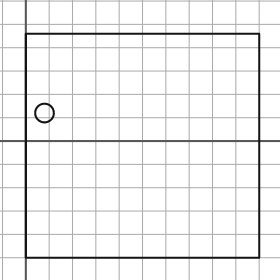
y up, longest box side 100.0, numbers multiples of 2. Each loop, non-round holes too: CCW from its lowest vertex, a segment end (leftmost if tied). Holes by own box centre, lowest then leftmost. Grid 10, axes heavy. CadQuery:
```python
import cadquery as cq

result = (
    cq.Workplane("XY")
    .moveTo(0.0, -50.0)
    .lineTo(100.0, -50.0)
    .lineTo(100.0, 46.0)
    .lineTo(0.0, 46.0)
    .close()
    .moveTo(8.0, 12.0)
    .circle(4.0)
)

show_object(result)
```